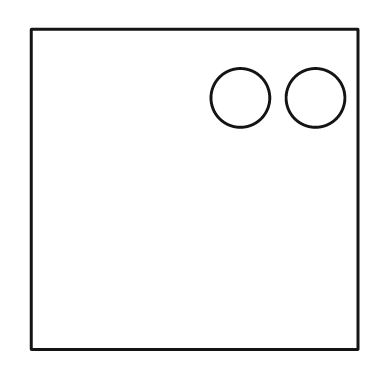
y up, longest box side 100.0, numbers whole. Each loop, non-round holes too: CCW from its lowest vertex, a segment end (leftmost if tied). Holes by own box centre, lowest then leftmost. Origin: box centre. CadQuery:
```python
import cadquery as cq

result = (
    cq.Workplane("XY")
    .moveTo(-50.0, -49.0)
    .lineTo(50.0, -49.0)
    .lineTo(50.0, 49.0)
    .lineTo(-50.0, 49.0)
    .close()
    .moveTo(14.0, 28.0)
    .circle(9.0)
    .moveTo(37.0, 28.0)
    .circle(9.0)
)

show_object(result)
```